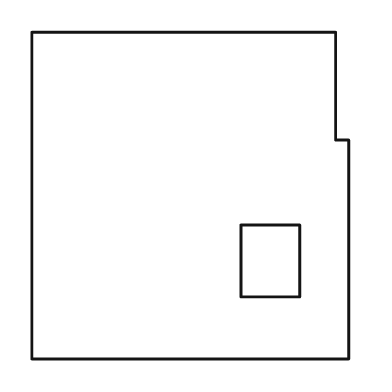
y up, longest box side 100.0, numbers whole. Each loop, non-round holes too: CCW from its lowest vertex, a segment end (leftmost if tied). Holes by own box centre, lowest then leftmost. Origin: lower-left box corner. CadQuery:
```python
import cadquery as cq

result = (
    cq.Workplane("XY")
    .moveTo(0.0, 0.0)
    .lineTo(97.0, 0.0)
    .lineTo(97.0, 67.0)
    .lineTo(93.0, 67.0)
    .lineTo(93.0, 100.0)
    .lineTo(0.0, 100.0)
    .close()
    .moveTo(64.0, 19.0)
    .lineTo(82.0, 19.0)
    .lineTo(82.0, 41.0)
    .lineTo(64.0, 41.0)
    .close()
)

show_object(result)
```